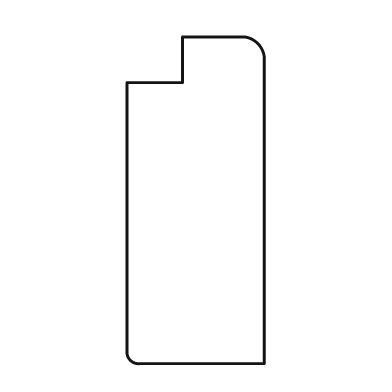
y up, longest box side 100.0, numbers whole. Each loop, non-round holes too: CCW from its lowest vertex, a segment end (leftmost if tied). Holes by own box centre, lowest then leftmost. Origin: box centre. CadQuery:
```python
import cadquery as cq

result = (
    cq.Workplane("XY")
    .moveTo(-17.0, -50.0)
    .lineTo(21.0, -50.0)
    .lineTo(21.0, 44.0)
    .threePointArc((19.0, 48.0), (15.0, 50.0))
    .lineTo(-4.0, 50.0)
    .lineTo(-4.0, 36.0)
    .lineTo(-21.0, 36.0)
    .lineTo(-21.0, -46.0)
    .threePointArc((-20.0, -49.0), (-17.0, -50.0))
    .close()
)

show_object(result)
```